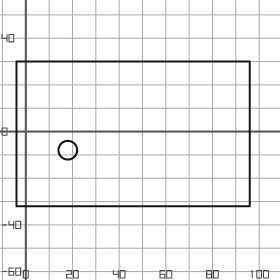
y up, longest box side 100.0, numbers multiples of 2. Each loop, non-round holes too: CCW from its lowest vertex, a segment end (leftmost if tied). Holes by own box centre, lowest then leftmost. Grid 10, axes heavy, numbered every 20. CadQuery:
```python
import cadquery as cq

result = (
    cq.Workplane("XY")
    .moveTo(-4.0, -32.0)
    .lineTo(96.0, -32.0)
    .lineTo(96.0, 30.0)
    .lineTo(-4.0, 30.0)
    .close()
    .moveTo(18.0, -8.0)
    .circle(4.0)
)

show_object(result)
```